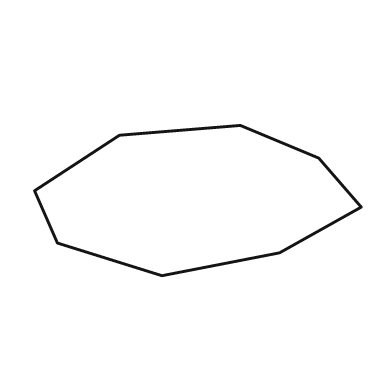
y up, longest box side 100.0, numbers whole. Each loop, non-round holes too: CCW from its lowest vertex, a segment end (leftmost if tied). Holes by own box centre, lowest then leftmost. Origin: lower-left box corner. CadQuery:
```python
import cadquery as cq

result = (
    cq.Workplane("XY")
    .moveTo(39.0, 0.0)
    .lineTo(75.0, 7.0)
    .lineTo(100.0, 21.0)
    .lineTo(87.0, 36.0)
    .lineTo(63.0, 46.0)
    .lineTo(26.0, 43.0)
    .lineTo(0.0, 26.0)
    .lineTo(7.0, 10.0)
    .close()
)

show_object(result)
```